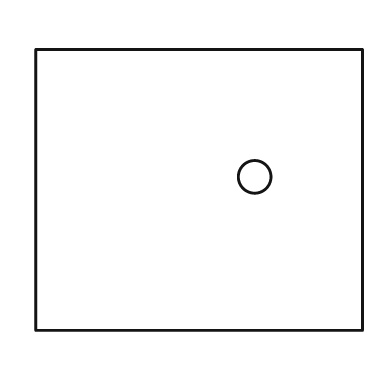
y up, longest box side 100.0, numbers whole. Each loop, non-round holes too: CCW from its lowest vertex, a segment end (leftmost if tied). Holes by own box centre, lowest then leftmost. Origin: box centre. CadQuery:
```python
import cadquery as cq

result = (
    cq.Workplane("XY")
    .moveTo(-50.0, -43.0)
    .lineTo(50.0, -43.0)
    .lineTo(50.0, 43.0)
    .lineTo(-50.0, 43.0)
    .close()
    .moveTo(17.0, 4.0)
    .circle(5.0)
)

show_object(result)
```